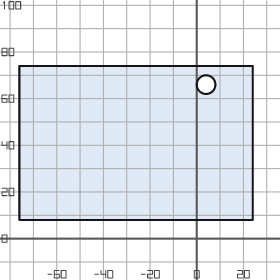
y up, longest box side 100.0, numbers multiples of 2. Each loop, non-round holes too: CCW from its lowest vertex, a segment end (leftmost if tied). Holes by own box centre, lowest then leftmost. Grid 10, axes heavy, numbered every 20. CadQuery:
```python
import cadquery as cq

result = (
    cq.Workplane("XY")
    .moveTo(-76.0, 8.0)
    .lineTo(24.0, 8.0)
    .lineTo(24.0, 74.0)
    .lineTo(-76.0, 74.0)
    .close()
    .moveTo(4.0, 66.0)
    .circle(4.0)
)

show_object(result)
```